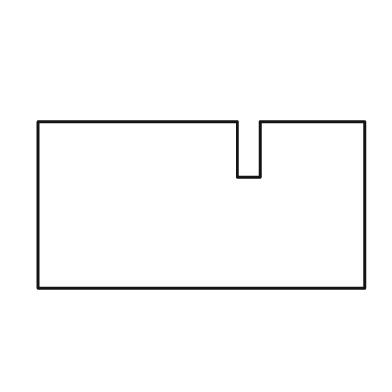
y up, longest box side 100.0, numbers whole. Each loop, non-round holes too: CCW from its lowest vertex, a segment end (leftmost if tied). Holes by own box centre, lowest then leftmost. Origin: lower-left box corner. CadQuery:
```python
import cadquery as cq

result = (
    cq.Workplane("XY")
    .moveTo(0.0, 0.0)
    .lineTo(100.0, 0.0)
    .lineTo(100.0, 51.0)
    .lineTo(68.0, 51.0)
    .lineTo(68.0, 34.0)
    .lineTo(61.0, 34.0)
    .lineTo(61.0, 51.0)
    .lineTo(0.0, 51.0)
    .close()
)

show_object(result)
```